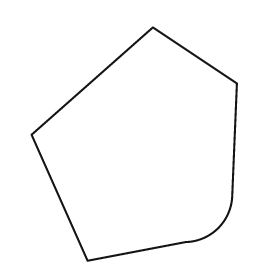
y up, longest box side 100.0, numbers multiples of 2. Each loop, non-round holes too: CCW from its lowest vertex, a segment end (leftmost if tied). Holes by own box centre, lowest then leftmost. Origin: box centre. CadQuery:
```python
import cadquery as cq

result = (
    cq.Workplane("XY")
    .moveTo(-20.0, -50.0)
    .lineTo(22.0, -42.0)
    .threePointArc((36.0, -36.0), (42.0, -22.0))
    .lineTo(44.0, 26.0)
    .lineTo(8.0, 50.0)
    .lineTo(-44.0, 4.0)
    .close()
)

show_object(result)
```